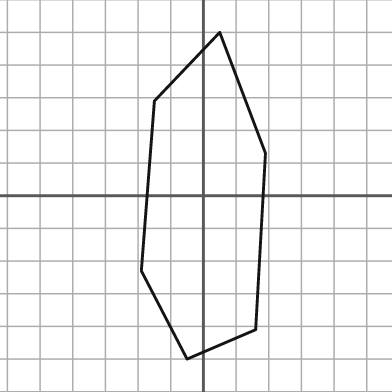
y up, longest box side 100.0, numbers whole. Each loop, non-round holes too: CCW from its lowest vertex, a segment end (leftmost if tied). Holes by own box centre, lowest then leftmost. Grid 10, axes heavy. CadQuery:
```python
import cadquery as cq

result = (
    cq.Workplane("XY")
    .moveTo(-5.0, -50.0)
    .lineTo(16.0, -41.0)
    .lineTo(19.0, 13.0)
    .lineTo(5.0, 50.0)
    .lineTo(-15.0, 29.0)
    .lineTo(-19.0, -23.0)
    .close()
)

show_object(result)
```